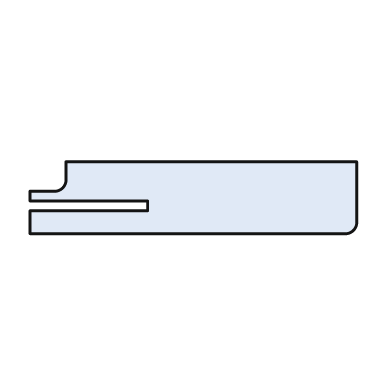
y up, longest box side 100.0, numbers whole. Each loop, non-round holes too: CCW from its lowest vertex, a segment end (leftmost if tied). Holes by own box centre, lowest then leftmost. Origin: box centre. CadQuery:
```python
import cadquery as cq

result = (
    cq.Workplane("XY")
    .moveTo(-50.0, -11.0)
    .lineTo(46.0, -11.0)
    .threePointArc((49.0, -10.0), (50.0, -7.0))
    .lineTo(50.0, 11.0)
    .lineTo(-39.0, 11.0)
    .lineTo(-39.0, 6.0)
    .threePointArc((-40.0, 3.0), (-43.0, 2.0))
    .lineTo(-50.0, 2.0)
    .lineTo(-50.0, -1.0)
    .lineTo(-14.0, -1.0)
    .lineTo(-14.0, -4.0)
    .lineTo(-50.0, -4.0)
    .close()
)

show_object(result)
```